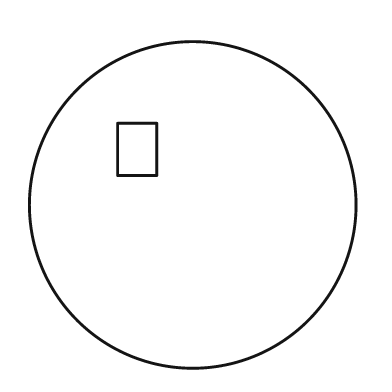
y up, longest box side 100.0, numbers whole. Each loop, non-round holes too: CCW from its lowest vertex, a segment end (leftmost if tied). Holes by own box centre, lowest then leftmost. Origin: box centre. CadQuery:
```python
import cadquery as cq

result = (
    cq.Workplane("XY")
    .moveTo(0.0, 0.0)
    .circle(50.0)
    .moveTo(-23.0, 9.0)
    .lineTo(-11.0, 9.0)
    .lineTo(-11.0, 25.0)
    .lineTo(-23.0, 25.0)
    .close()
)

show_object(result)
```